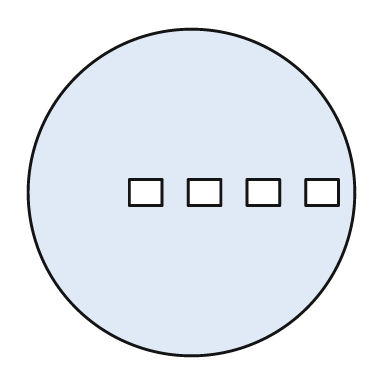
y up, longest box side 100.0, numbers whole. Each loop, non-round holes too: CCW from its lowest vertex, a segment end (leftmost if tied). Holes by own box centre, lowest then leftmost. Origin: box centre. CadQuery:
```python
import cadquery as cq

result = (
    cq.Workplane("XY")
    .moveTo(0.0, 0.0)
    .circle(50.0)
    .moveTo(-19.0, -4.0)
    .lineTo(-9.0, -4.0)
    .lineTo(-9.0, 4.0)
    .lineTo(-19.0, 4.0)
    .close()
    .moveTo(-1.0, -4.0)
    .lineTo(9.0, -4.0)
    .lineTo(9.0, 4.0)
    .lineTo(-1.0, 4.0)
    .close()
    .moveTo(17.0, -4.0)
    .lineTo(27.0, -4.0)
    .lineTo(27.0, 4.0)
    .lineTo(17.0, 4.0)
    .close()
    .moveTo(35.0, -4.0)
    .lineTo(45.0, -4.0)
    .lineTo(45.0, 4.0)
    .lineTo(35.0, 4.0)
    .close()
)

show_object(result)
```